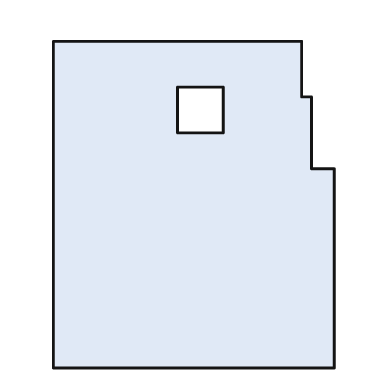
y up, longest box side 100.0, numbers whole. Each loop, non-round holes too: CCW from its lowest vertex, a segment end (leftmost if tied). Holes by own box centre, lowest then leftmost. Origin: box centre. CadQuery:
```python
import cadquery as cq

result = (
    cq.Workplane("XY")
    .moveTo(-43.0, -50.0)
    .lineTo(43.0, -50.0)
    .lineTo(43.0, 11.0)
    .lineTo(36.0, 11.0)
    .lineTo(36.0, 33.0)
    .lineTo(33.0, 33.0)
    .lineTo(33.0, 50.0)
    .lineTo(-43.0, 50.0)
    .close()
    .moveTo(-5.0, 22.0)
    .lineTo(9.0, 22.0)
    .lineTo(9.0, 36.0)
    .lineTo(-5.0, 36.0)
    .close()
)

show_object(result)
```